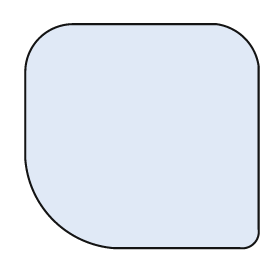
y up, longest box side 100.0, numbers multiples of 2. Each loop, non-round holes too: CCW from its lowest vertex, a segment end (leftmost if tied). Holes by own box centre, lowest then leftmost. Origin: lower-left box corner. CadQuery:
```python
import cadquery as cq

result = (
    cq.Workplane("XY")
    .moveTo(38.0, 0.0)
    .lineTo(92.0, 0.0)
    .threePointArc((98.0, 2.0), (100.0, 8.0))
    .lineTo(100.0, 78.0)
    .threePointArc((94.0, 90.0), (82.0, 96.0))
    .lineTo(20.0, 96.0)
    .threePointArc((6.0, 90.0), (0.0, 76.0))
    .lineTo(0.0, 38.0)
    .threePointArc((12.0, 12.0), (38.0, 0.0))
    .close()
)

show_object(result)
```